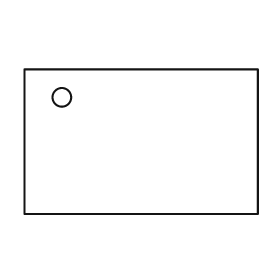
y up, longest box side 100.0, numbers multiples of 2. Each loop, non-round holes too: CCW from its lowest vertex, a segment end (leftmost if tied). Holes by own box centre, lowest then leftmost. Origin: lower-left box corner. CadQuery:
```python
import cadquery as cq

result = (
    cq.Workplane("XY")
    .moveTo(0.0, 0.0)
    .lineTo(100.0, 0.0)
    .lineTo(100.0, 62.0)
    .lineTo(0.0, 62.0)
    .close()
    .moveTo(16.0, 50.0)
    .circle(4.0)
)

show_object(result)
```